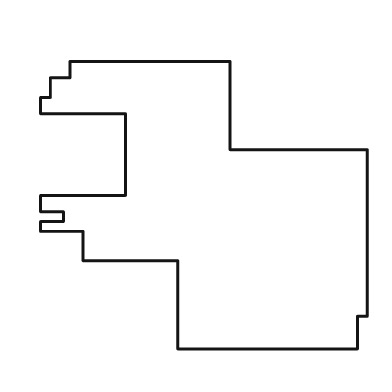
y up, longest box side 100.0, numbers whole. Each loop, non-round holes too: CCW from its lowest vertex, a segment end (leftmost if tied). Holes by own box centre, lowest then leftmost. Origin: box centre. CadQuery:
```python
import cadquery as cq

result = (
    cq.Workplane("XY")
    .moveTo(-8.0, -44.0)
    .lineTo(47.0, -44.0)
    .lineTo(47.0, -34.0)
    .lineTo(50.0, -34.0)
    .lineTo(50.0, 17.0)
    .lineTo(8.0, 17.0)
    .lineTo(8.0, 44.0)
    .lineTo(-41.0, 44.0)
    .lineTo(-41.0, 39.0)
    .lineTo(-47.0, 39.0)
    .lineTo(-47.0, 33.0)
    .lineTo(-50.0, 33.0)
    .lineTo(-50.0, 28.0)
    .lineTo(-24.0, 28.0)
    .lineTo(-24.0, 3.0)
    .lineTo(-50.0, 3.0)
    .lineTo(-50.0, -2.0)
    .lineTo(-43.0, -2.0)
    .lineTo(-43.0, -5.0)
    .lineTo(-50.0, -5.0)
    .lineTo(-50.0, -8.0)
    .lineTo(-37.0, -8.0)
    .lineTo(-37.0, -17.0)
    .lineTo(-8.0, -17.0)
    .close()
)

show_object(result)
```